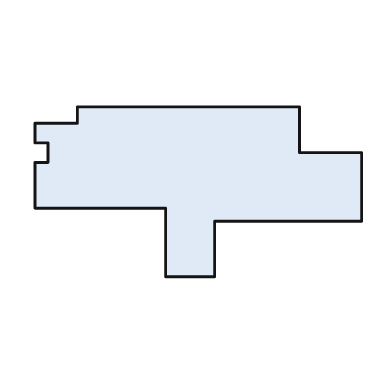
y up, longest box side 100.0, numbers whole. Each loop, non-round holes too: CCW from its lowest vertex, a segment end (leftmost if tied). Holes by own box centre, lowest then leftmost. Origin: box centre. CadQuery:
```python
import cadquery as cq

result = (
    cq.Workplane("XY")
    .moveTo(-10.0, -26.0)
    .lineTo(5.0, -26.0)
    .lineTo(5.0, -9.0)
    .lineTo(50.0, -9.0)
    .lineTo(50.0, 12.0)
    .lineTo(31.0, 12.0)
    .lineTo(31.0, 26.0)
    .lineTo(-37.0, 26.0)
    .lineTo(-37.0, 21.0)
    .lineTo(-50.0, 21.0)
    .lineTo(-50.0, 15.0)
    .lineTo(-46.0, 15.0)
    .lineTo(-46.0, 9.0)
    .lineTo(-50.0, 9.0)
    .lineTo(-50.0, -5.0)
    .lineTo(-10.0, -5.0)
    .close()
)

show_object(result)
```